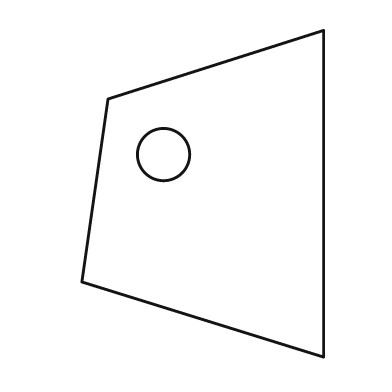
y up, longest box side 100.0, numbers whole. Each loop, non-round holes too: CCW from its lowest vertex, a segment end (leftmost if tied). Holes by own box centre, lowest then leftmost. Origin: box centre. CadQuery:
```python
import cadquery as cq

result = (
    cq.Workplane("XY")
    .moveTo(37.0, -50.0)
    .lineTo(37.0, 50.0)
    .lineTo(-29.0, 29.0)
    .lineTo(-37.0, -27.0)
    .close()
    .moveTo(-12.0, 12.0)
    .circle(8.0)
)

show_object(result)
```